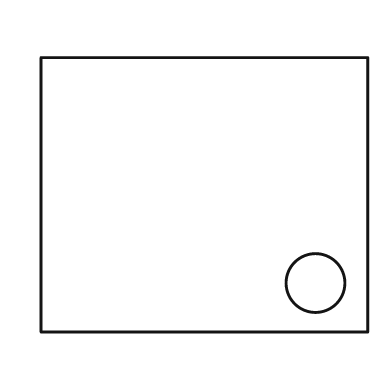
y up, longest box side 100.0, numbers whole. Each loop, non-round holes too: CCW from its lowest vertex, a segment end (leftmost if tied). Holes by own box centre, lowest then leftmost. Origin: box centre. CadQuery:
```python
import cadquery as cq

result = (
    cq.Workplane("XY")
    .moveTo(-50.0, -42.0)
    .lineTo(50.0, -42.0)
    .lineTo(50.0, 42.0)
    .lineTo(-50.0, 42.0)
    .close()
    .moveTo(34.0, -27.0)
    .circle(9.0)
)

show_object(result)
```